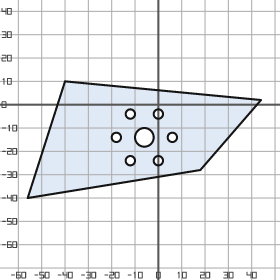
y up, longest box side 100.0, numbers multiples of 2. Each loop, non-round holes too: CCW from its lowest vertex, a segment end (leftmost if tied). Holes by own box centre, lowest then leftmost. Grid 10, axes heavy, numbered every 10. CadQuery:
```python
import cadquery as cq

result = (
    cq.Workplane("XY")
    .moveTo(-56.0, -40.0)
    .lineTo(18.0, -28.0)
    .lineTo(44.0, 2.0)
    .lineTo(-40.0, 10.0)
    .close()
    .moveTo(-12.0, -24.0)
    .circle(2.0)
    .moveTo(0.0, -24.0)
    .circle(2.0)
    .moveTo(-18.0, -14.0)
    .circle(2.0)
    .moveTo(-6.0, -14.0)
    .circle(4.0)
    .moveTo(6.0, -14.0)
    .circle(2.0)
    .moveTo(-12.0, -4.0)
    .circle(2.0)
    .moveTo(0.0, -4.0)
    .circle(2.0)
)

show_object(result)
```